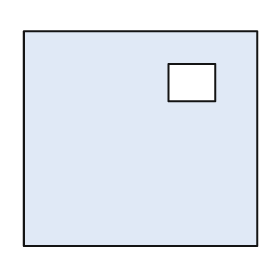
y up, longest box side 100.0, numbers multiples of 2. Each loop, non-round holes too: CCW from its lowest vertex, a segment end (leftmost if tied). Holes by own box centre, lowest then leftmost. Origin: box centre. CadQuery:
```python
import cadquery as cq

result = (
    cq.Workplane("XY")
    .moveTo(-50.0, -46.0)
    .lineTo(50.0, -46.0)
    .lineTo(50.0, 46.0)
    .lineTo(-50.0, 46.0)
    .close()
    .moveTo(12.0, 16.0)
    .lineTo(32.0, 16.0)
    .lineTo(32.0, 32.0)
    .lineTo(12.0, 32.0)
    .close()
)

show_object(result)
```